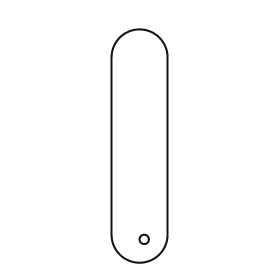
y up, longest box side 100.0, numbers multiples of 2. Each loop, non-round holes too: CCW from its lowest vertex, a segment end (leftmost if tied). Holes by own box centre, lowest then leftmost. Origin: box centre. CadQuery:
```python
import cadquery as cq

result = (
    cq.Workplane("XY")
    .moveTo(-12.0, -38.0)
    .threePointArc((0.0, -50.0), (12.0, -38.0))
    .lineTo(12.0, 38.0)
    .threePointArc((0.0, 50.0), (-12.0, 38.0))
    .close()
    .moveTo(2.0, -40.0)
    .circle(2.0)
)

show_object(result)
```